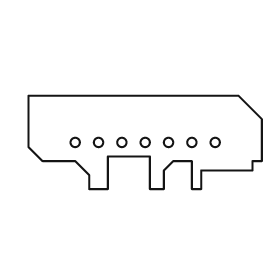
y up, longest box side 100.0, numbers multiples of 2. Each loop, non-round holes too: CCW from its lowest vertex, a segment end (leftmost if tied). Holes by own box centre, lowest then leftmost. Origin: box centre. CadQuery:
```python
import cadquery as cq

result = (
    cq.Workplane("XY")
    .moveTo(-24.0, -20.0)
    .lineTo(-16.0, -20.0)
    .lineTo(-16.0, -6.0)
    .lineTo(2.0, -6.0)
    .lineTo(2.0, -20.0)
    .lineTo(8.0, -20.0)
    .lineTo(8.0, -12.0)
    .lineTo(12.0, -8.0)
    .lineTo(20.0, -8.0)
    .lineTo(20.0, -20.0)
    .lineTo(24.0, -20.0)
    .lineTo(24.0, -12.0)
    .lineTo(46.0, -12.0)
    .lineTo(46.0, -8.0)
    .lineTo(50.0, -8.0)
    .lineTo(50.0, 10.0)
    .lineTo(40.0, 20.0)
    .lineTo(-50.0, 20.0)
    .lineTo(-50.0, -2.0)
    .lineTo(-44.0, -8.0)
    .lineTo(-30.0, -8.0)
    .lineTo(-24.0, -14.0)
    .close()
    .moveTo(-30.0, 0.0)
    .circle(2.0)
    .moveTo(-20.0, 0.0)
    .circle(2.0)
    .moveTo(-10.0, 0.0)
    .circle(2.0)
    .moveTo(0.0, 0.0)
    .circle(2.0)
    .moveTo(10.0, 0.0)
    .circle(2.0)
    .moveTo(20.0, 0.0)
    .circle(2.0)
    .moveTo(30.0, 0.0)
    .circle(2.0)
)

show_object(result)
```